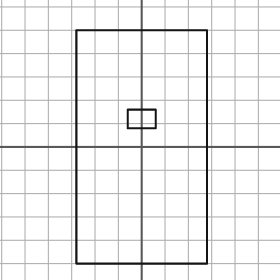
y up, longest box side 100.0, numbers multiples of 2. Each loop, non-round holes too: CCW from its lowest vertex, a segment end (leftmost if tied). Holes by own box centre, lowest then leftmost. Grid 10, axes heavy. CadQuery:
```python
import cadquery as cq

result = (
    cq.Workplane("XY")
    .moveTo(-28.0, -50.0)
    .lineTo(28.0, -50.0)
    .lineTo(28.0, 50.0)
    .lineTo(-28.0, 50.0)
    .close()
    .moveTo(-6.0, 8.0)
    .lineTo(6.0, 8.0)
    .lineTo(6.0, 16.0)
    .lineTo(-6.0, 16.0)
    .close()
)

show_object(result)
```